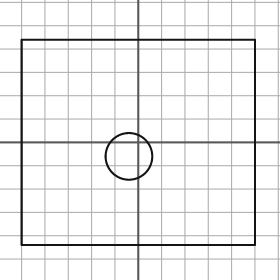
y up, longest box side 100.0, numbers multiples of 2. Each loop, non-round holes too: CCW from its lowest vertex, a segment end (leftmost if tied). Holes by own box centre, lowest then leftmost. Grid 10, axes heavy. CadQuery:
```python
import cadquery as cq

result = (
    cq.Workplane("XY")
    .moveTo(-50.0, -44.0)
    .lineTo(50.0, -44.0)
    .lineTo(50.0, 44.0)
    .lineTo(-50.0, 44.0)
    .close()
    .moveTo(-4.0, -6.0)
    .circle(10.0)
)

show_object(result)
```